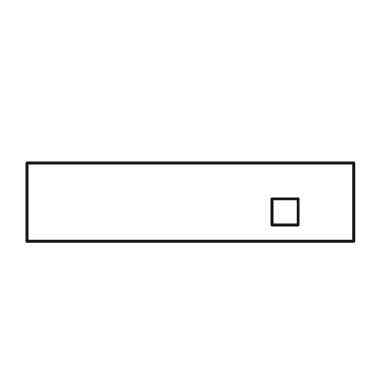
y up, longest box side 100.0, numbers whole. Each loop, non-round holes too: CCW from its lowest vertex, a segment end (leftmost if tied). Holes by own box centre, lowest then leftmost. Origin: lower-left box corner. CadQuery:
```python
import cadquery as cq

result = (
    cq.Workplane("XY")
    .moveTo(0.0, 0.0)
    .lineTo(100.0, 0.0)
    .lineTo(100.0, 24.0)
    .lineTo(0.0, 24.0)
    .close()
    .moveTo(75.0, 5.0)
    .lineTo(83.0, 5.0)
    .lineTo(83.0, 13.0)
    .lineTo(75.0, 13.0)
    .close()
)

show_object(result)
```